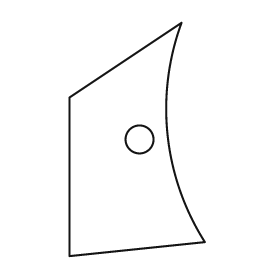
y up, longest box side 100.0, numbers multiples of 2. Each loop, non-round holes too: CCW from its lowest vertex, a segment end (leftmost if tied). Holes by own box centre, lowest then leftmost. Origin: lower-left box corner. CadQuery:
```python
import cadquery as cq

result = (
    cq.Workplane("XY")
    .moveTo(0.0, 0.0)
    .lineTo(58.0, 6.0)
    .threePointArc((42.0, 52.0), (48.0, 100.0))
    .lineTo(0.0, 68.0)
    .close()
    .moveTo(30.0, 50.0)
    .circle(6.0)
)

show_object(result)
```